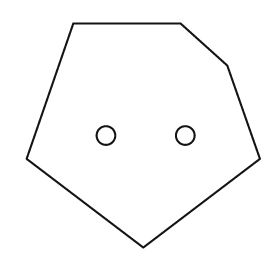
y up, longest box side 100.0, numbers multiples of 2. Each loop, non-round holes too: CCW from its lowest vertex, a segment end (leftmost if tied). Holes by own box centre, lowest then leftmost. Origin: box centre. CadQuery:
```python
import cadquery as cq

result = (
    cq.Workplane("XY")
    .moveTo(0.0, -48.0)
    .lineTo(50.0, -10.0)
    .lineTo(36.0, 30.0)
    .lineTo(16.0, 48.0)
    .lineTo(-30.0, 48.0)
    .lineTo(-50.0, -10.0)
    .close()
    .moveTo(-16.0, 0.0)
    .circle(4.0)
    .moveTo(18.0, 0.0)
    .circle(4.0)
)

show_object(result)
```